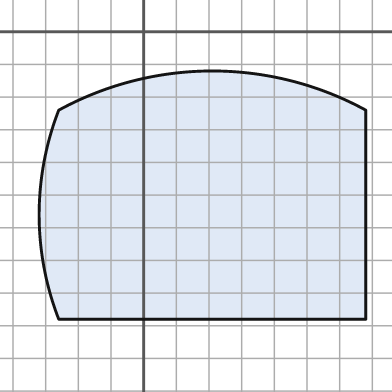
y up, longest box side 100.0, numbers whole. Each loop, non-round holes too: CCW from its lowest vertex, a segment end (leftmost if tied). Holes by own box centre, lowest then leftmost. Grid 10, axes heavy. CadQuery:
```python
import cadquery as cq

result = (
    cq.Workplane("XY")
    .moveTo(-26.0, -88.0)
    .lineTo(68.0, -88.0)
    .lineTo(68.0, -24.0)
    .threePointArc((21.0, -12.0), (-26.0, -24.0))
    .threePointArc((-32.0, -56.0), (-26.0, -88.0))
    .close()
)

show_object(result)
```